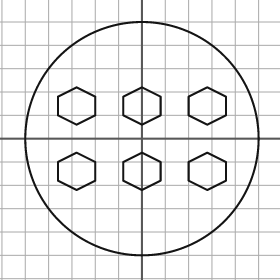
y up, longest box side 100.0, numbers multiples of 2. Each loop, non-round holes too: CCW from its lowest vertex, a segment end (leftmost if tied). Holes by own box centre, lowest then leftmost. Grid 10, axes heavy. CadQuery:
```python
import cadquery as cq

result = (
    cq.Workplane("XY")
    .moveTo(0.0, 0.0)
    .circle(50.0)
    .moveTo(-28.0, -22.0)
    .lineTo(-20.0, -18.0)
    .lineTo(-20.0, -10.0)
    .lineTo(-28.0, -6.0)
    .lineTo(-36.0, -10.0)
    .lineTo(-36.0, -18.0)
    .close()
    .moveTo(0.0, -22.0)
    .lineTo(8.0, -18.0)
    .lineTo(8.0, -10.0)
    .lineTo(0.0, -6.0)
    .lineTo(-8.0, -10.0)
    .lineTo(-8.0, -18.0)
    .close()
    .moveTo(28.0, -22.0)
    .lineTo(36.0, -18.0)
    .lineTo(36.0, -10.0)
    .lineTo(28.0, -6.0)
    .lineTo(20.0, -10.0)
    .lineTo(20.0, -18.0)
    .close()
    .moveTo(-28.0, 6.0)
    .lineTo(-20.0, 10.0)
    .lineTo(-20.0, 18.0)
    .lineTo(-28.0, 22.0)
    .lineTo(-36.0, 18.0)
    .lineTo(-36.0, 10.0)
    .close()
    .moveTo(0.0, 6.0)
    .lineTo(8.0, 10.0)
    .lineTo(8.0, 18.0)
    .lineTo(0.0, 22.0)
    .lineTo(-8.0, 18.0)
    .lineTo(-8.0, 10.0)
    .close()
    .moveTo(28.0, 6.0)
    .lineTo(36.0, 10.0)
    .lineTo(36.0, 18.0)
    .lineTo(28.0, 22.0)
    .lineTo(20.0, 18.0)
    .lineTo(20.0, 10.0)
    .close()
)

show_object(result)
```